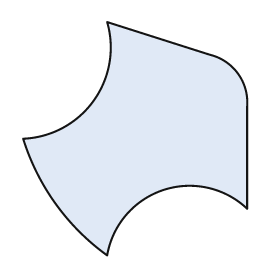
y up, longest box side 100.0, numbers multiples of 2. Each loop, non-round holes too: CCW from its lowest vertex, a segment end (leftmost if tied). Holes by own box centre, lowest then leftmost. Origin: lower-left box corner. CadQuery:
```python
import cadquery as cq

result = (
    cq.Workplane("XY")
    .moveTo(36.0, 0.0)
    .threePointArc((60.0, 28.0), (96.0, 20.0))
    .lineTo(96.0, 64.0)
    .threePointArc((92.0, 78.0), (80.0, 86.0))
    .lineTo(36.0, 100.0)
    .threePointArc((30.0, 66.0), (0.0, 50.0))
    .threePointArc((14.0, 22.0), (36.0, 0.0))
    .close()
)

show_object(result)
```